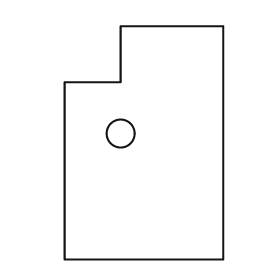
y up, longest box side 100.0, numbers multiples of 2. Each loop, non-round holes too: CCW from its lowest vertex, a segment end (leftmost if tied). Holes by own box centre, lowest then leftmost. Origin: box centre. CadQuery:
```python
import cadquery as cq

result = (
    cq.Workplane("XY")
    .moveTo(-34.0, -50.0)
    .lineTo(34.0, -50.0)
    .lineTo(34.0, 50.0)
    .lineTo(-10.0, 50.0)
    .lineTo(-10.0, 26.0)
    .lineTo(-34.0, 26.0)
    .close()
    .moveTo(-10.0, 4.0)
    .circle(6.0)
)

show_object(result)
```